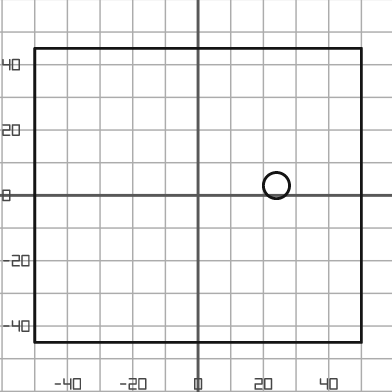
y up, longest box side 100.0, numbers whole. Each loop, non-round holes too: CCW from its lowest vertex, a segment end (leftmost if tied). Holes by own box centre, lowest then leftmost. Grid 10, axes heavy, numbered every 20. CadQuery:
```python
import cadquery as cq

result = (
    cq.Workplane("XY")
    .moveTo(-50.0, -45.0)
    .lineTo(50.0, -45.0)
    .lineTo(50.0, 45.0)
    .lineTo(-50.0, 45.0)
    .close()
    .moveTo(24.0, 3.0)
    .circle(4.0)
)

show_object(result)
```